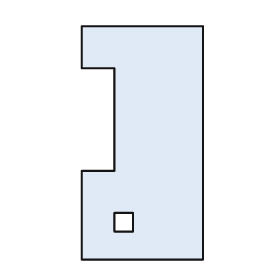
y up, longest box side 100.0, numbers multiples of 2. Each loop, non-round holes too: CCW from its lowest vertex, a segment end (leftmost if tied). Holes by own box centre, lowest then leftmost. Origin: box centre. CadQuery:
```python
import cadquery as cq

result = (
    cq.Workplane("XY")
    .moveTo(-26.0, -50.0)
    .lineTo(26.0, -50.0)
    .lineTo(26.0, 50.0)
    .lineTo(-26.0, 50.0)
    .lineTo(-26.0, 32.0)
    .lineTo(-12.0, 32.0)
    .lineTo(-12.0, -12.0)
    .lineTo(-26.0, -12.0)
    .close()
    .moveTo(-12.0, -38.0)
    .lineTo(-4.0, -38.0)
    .lineTo(-4.0, -30.0)
    .lineTo(-12.0, -30.0)
    .close()
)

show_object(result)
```